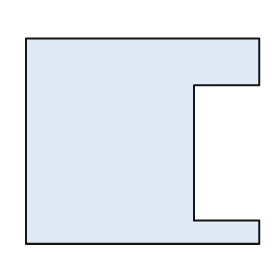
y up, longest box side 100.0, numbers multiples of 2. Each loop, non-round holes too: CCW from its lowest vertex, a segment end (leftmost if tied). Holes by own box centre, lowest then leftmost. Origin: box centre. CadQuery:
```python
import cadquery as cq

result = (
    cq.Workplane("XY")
    .moveTo(-50.0, -44.0)
    .lineTo(50.0, -44.0)
    .lineTo(50.0, -34.0)
    .lineTo(22.0, -34.0)
    .lineTo(22.0, 24.0)
    .lineTo(50.0, 24.0)
    .lineTo(50.0, 44.0)
    .lineTo(-50.0, 44.0)
    .close()
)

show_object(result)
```